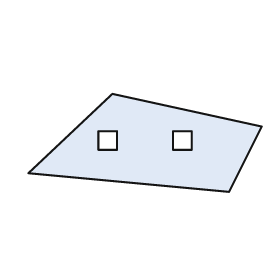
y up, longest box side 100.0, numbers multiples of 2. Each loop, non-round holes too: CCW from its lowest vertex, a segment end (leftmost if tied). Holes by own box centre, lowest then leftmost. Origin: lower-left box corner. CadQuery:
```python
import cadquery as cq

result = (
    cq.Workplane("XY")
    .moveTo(86.0, 0.0)
    .lineTo(100.0, 28.0)
    .lineTo(36.0, 42.0)
    .lineTo(0.0, 8.0)
    .close()
    .moveTo(30.0, 18.0)
    .lineTo(38.0, 18.0)
    .lineTo(38.0, 26.0)
    .lineTo(30.0, 26.0)
    .close()
    .moveTo(62.0, 18.0)
    .lineTo(70.0, 18.0)
    .lineTo(70.0, 26.0)
    .lineTo(62.0, 26.0)
    .close()
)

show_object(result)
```